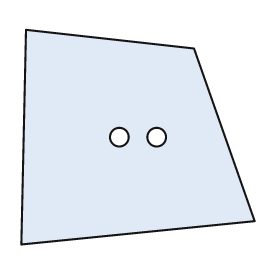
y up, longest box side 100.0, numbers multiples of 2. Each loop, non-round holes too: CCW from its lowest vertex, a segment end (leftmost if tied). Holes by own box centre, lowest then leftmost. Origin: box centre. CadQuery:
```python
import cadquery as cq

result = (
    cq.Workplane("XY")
    .moveTo(-50.0, -46.0)
    .lineTo(50.0, -36.0)
    .lineTo(24.0, 38.0)
    .lineTo(-48.0, 46.0)
    .close()
    .moveTo(-8.0, 0.0)
    .circle(4.0)
    .moveTo(8.0, 0.0)
    .circle(4.0)
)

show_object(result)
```